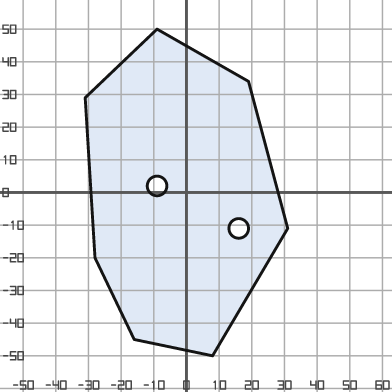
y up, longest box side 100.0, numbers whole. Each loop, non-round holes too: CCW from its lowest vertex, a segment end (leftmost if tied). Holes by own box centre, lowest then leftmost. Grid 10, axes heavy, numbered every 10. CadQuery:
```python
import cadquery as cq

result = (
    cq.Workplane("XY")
    .moveTo(8.0, -50.0)
    .lineTo(31.0, -11.0)
    .lineTo(19.0, 34.0)
    .lineTo(-9.0, 50.0)
    .lineTo(-31.0, 29.0)
    .lineTo(-28.0, -20.0)
    .lineTo(-16.0, -45.0)
    .close()
    .moveTo(16.0, -11.0)
    .circle(3.0)
    .moveTo(-9.0, 2.0)
    .circle(3.0)
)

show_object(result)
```